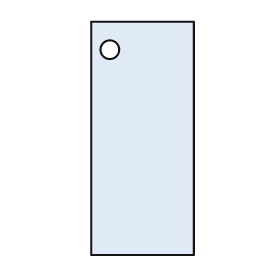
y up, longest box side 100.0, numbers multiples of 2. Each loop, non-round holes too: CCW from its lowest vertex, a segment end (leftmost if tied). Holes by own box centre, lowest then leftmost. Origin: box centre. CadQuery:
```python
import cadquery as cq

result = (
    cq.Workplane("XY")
    .moveTo(-22.0, -50.0)
    .lineTo(22.0, -50.0)
    .lineTo(22.0, 50.0)
    .lineTo(-22.0, 50.0)
    .close()
    .moveTo(-14.0, 38.0)
    .circle(4.0)
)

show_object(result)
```